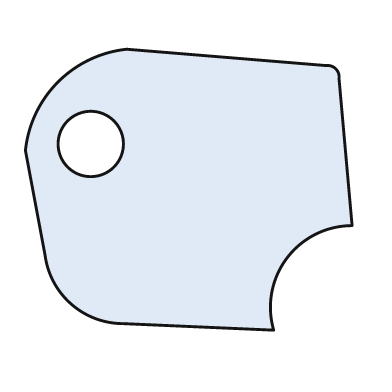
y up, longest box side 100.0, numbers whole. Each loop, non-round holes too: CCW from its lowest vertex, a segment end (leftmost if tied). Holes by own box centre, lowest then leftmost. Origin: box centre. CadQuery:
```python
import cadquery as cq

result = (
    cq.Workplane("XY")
    .moveTo(26.0, -43.0)
    .threePointArc((30.0, -21.0), (50.0, -11.0))
    .lineTo(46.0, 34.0)
    .threePointArc((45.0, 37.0), (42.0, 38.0))
    .lineTo(-19.0, 43.0)
    .threePointArc((-40.0, 33.0), (-50.0, 12.0))
    .lineTo(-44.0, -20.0)
    .threePointArc((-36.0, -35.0), (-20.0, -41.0))
    .close()
    .moveTo(-30.0, 14.0)
    .circle(10.0)
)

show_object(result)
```